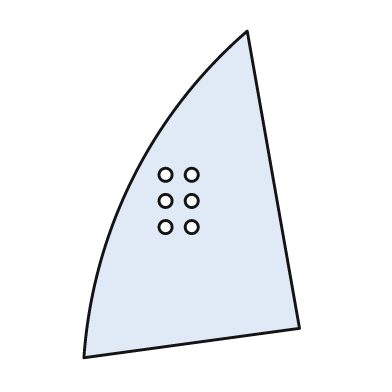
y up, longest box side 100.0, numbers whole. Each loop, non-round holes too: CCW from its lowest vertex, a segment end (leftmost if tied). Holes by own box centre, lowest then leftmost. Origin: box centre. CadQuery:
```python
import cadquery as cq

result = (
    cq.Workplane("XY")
    .moveTo(-33.0, -50.0)
    .lineTo(33.0, -41.0)
    .lineTo(17.0, 50.0)
    .threePointArc((-18.0, 5.0), (-33.0, -50.0))
    .close()
    .moveTo(-8.0, -10.0)
    .circle(2.0)
    .moveTo(0.0, -10.0)
    .circle(2.0)
    .moveTo(-8.0, -2.0)
    .circle(2.0)
    .moveTo(0.0, -2.0)
    .circle(2.0)
    .moveTo(-8.0, 6.0)
    .circle(2.0)
    .moveTo(0.0, 6.0)
    .circle(2.0)
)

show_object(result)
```